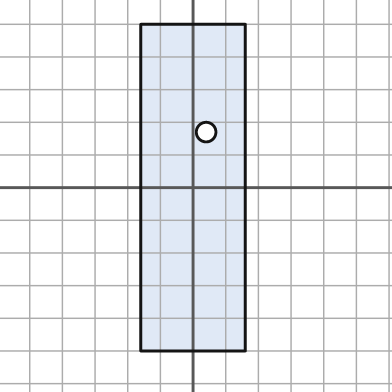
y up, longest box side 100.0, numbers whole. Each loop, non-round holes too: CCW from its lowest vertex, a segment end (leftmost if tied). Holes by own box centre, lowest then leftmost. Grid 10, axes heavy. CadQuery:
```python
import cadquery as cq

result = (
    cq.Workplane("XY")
    .moveTo(-16.0, -50.0)
    .lineTo(16.0, -50.0)
    .lineTo(16.0, 50.0)
    .lineTo(-16.0, 50.0)
    .close()
    .moveTo(4.0, 17.0)
    .circle(3.0)
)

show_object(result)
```